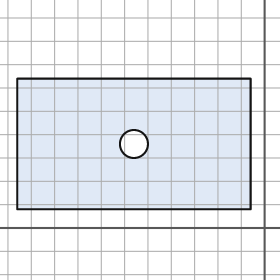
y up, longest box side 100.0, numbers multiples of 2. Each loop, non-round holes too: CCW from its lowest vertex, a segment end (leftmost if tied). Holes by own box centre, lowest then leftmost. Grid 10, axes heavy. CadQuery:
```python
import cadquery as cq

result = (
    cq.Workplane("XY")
    .moveTo(-106.0, 8.0)
    .lineTo(-6.0, 8.0)
    .lineTo(-6.0, 64.0)
    .lineTo(-106.0, 64.0)
    .close()
    .moveTo(-56.0, 36.0)
    .circle(6.0)
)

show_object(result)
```